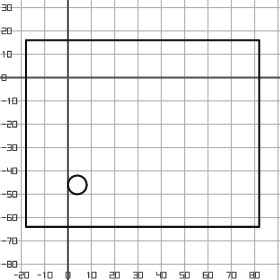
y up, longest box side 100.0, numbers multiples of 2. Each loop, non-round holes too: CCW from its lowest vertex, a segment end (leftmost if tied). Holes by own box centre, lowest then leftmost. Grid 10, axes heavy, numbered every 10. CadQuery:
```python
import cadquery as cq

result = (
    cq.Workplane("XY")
    .moveTo(-18.0, -64.0)
    .lineTo(82.0, -64.0)
    .lineTo(82.0, 16.0)
    .lineTo(-18.0, 16.0)
    .close()
    .moveTo(4.0, -46.0)
    .circle(4.0)
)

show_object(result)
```